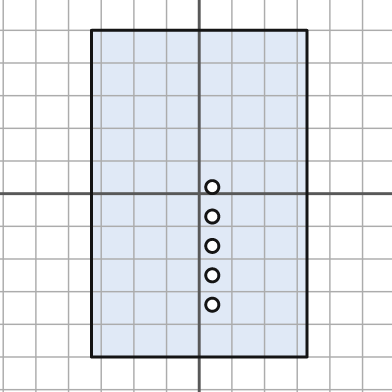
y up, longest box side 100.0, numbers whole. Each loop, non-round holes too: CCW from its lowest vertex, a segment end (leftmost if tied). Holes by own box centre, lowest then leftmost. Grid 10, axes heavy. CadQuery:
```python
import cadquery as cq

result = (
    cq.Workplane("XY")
    .moveTo(-33.0, -50.0)
    .lineTo(33.0, -50.0)
    .lineTo(33.0, 50.0)
    .lineTo(-33.0, 50.0)
    .close()
    .moveTo(4.0, -34.0)
    .circle(2.0)
    .moveTo(4.0, -25.0)
    .circle(2.0)
    .moveTo(4.0, -16.0)
    .circle(2.0)
    .moveTo(4.0, -7.0)
    .circle(2.0)
    .moveTo(4.0, 2.0)
    .circle(2.0)
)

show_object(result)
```